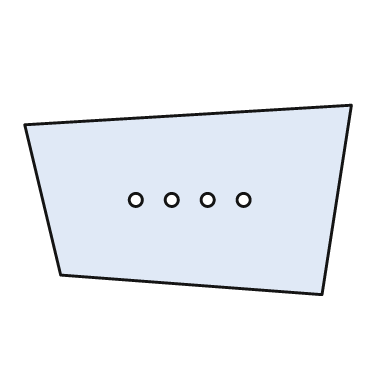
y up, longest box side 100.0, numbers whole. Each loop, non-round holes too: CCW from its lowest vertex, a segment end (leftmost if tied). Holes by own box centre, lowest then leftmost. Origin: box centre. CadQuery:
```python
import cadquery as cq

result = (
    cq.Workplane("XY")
    .moveTo(41.0, -29.0)
    .lineTo(50.0, 29.0)
    .lineTo(-50.0, 23.0)
    .lineTo(-39.0, -23.0)
    .close()
    .moveTo(-16.0, 0.0)
    .circle(2.0)
    .moveTo(-5.0, 0.0)
    .circle(2.0)
    .moveTo(6.0, 0.0)
    .circle(2.0)
    .moveTo(17.0, 0.0)
    .circle(2.0)
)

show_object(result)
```